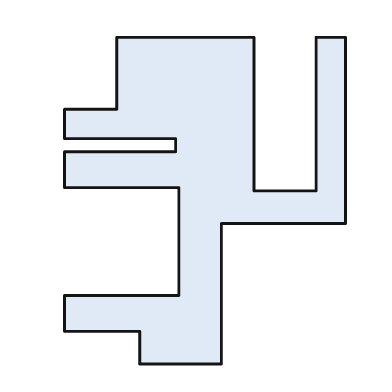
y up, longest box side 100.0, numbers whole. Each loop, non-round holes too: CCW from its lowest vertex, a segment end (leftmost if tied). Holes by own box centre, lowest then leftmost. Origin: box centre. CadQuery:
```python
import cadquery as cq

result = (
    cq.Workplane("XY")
    .moveTo(-20.0, -50.0)
    .lineTo(5.0, -50.0)
    .lineTo(5.0, -7.0)
    .lineTo(43.0, -7.0)
    .lineTo(43.0, 50.0)
    .lineTo(34.0, 50.0)
    .lineTo(34.0, 3.0)
    .lineTo(15.0, 3.0)
    .lineTo(15.0, 50.0)
    .lineTo(-27.0, 50.0)
    .lineTo(-27.0, 28.0)
    .lineTo(-43.0, 28.0)
    .lineTo(-43.0, 19.0)
    .lineTo(-9.0, 19.0)
    .lineTo(-9.0, 15.0)
    .lineTo(-43.0, 15.0)
    .lineTo(-43.0, 4.0)
    .lineTo(-8.0, 4.0)
    .lineTo(-8.0, -29.0)
    .lineTo(-43.0, -29.0)
    .lineTo(-43.0, -40.0)
    .lineTo(-20.0, -40.0)
    .close()
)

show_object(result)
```